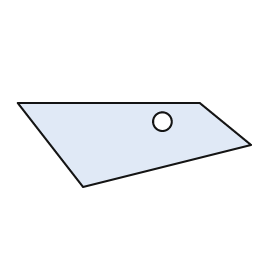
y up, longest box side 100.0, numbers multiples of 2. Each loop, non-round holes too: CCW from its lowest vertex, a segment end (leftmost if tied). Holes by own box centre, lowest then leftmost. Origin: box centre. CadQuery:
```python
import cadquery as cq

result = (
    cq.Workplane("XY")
    .moveTo(-22.0, -18.0)
    .lineTo(50.0, 0.0)
    .lineTo(28.0, 18.0)
    .lineTo(-50.0, 18.0)
    .close()
    .moveTo(12.0, 10.0)
    .circle(4.0)
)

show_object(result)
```